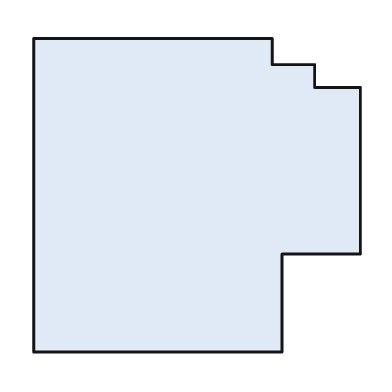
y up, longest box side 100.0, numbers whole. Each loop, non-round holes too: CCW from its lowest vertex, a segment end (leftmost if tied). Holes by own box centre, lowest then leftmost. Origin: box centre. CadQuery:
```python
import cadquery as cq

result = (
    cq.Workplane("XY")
    .moveTo(-50.0, -48.0)
    .lineTo(26.0, -48.0)
    .lineTo(26.0, -18.0)
    .lineTo(50.0, -18.0)
    .lineTo(50.0, 33.0)
    .lineTo(36.0, 33.0)
    .lineTo(36.0, 40.0)
    .lineTo(23.0, 40.0)
    .lineTo(23.0, 48.0)
    .lineTo(-50.0, 48.0)
    .close()
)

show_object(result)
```